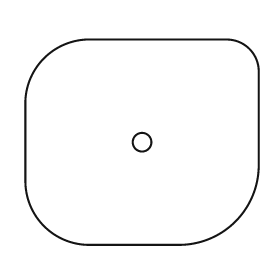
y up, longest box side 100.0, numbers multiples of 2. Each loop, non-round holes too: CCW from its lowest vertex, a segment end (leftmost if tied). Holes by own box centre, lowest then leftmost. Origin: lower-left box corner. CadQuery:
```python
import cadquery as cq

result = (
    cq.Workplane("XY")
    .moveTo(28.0, 0.0)
    .lineTo(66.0, 0.0)
    .threePointArc((90.0, 10.0), (100.0, 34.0))
    .lineTo(100.0, 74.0)
    .threePointArc((96.0, 84.0), (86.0, 88.0))
    .lineTo(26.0, 88.0)
    .threePointArc((8.0, 80.0), (0.0, 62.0))
    .lineTo(0.0, 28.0)
    .threePointArc((8.0, 8.0), (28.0, 0.0))
    .close()
    .moveTo(50.0, 44.0)
    .circle(4.0)
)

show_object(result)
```